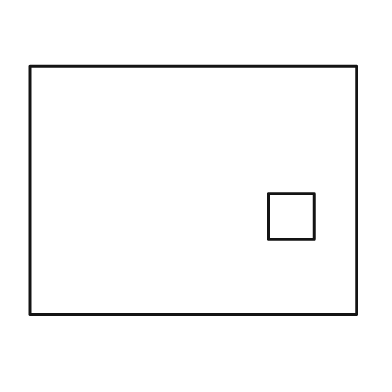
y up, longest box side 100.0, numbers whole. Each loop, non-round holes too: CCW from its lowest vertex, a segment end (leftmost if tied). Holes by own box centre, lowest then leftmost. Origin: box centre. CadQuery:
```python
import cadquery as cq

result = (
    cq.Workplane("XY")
    .moveTo(-50.0, -38.0)
    .lineTo(50.0, -38.0)
    .lineTo(50.0, 38.0)
    .lineTo(-50.0, 38.0)
    .close()
    .moveTo(23.0, -15.0)
    .lineTo(37.0, -15.0)
    .lineTo(37.0, -1.0)
    .lineTo(23.0, -1.0)
    .close()
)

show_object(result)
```